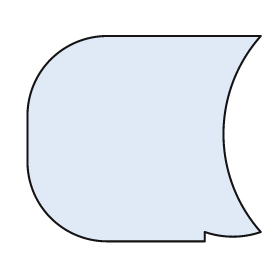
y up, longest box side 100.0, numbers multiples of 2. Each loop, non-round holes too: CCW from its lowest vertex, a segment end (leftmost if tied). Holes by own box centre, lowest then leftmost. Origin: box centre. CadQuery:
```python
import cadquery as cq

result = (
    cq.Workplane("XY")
    .moveTo(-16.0, -44.0)
    .lineTo(26.0, -44.0)
    .lineTo(26.0, -40.0)
    .threePointArc((38.0, -42.0), (50.0, -40.0))
    .threePointArc((34.0, 2.0), (50.0, 44.0))
    .lineTo(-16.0, 44.0)
    .threePointArc((-40.0, 34.0), (-50.0, 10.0))
    .lineTo(-50.0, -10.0)
    .threePointArc((-40.0, -34.0), (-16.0, -44.0))
    .close()
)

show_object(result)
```